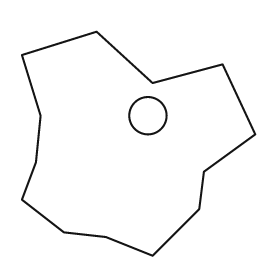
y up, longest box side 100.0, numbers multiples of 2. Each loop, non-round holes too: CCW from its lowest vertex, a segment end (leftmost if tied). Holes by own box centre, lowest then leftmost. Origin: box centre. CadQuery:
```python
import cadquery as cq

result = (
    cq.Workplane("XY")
    .moveTo(6.0, -48.0)
    .lineTo(26.0, -28.0)
    .lineTo(28.0, -12.0)
    .lineTo(50.0, 4.0)
    .lineTo(36.0, 34.0)
    .lineTo(6.0, 26.0)
    .lineTo(-18.0, 48.0)
    .lineTo(-50.0, 38.0)
    .lineTo(-42.0, 12.0)
    .lineTo(-44.0, -8.0)
    .lineTo(-50.0, -24.0)
    .lineTo(-32.0, -38.0)
    .lineTo(-14.0, -40.0)
    .close()
    .moveTo(4.0, 12.0)
    .circle(8.0)
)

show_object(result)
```